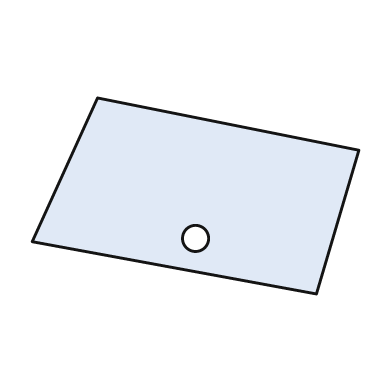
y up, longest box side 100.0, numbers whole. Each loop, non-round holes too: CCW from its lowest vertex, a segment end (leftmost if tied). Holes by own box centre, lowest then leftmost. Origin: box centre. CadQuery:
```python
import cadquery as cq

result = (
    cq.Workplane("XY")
    .moveTo(37.0, -30.0)
    .lineTo(50.0, 14.0)
    .lineTo(-30.0, 30.0)
    .lineTo(-50.0, -14.0)
    .close()
    .moveTo(0.0, -13.0)
    .circle(4.0)
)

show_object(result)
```